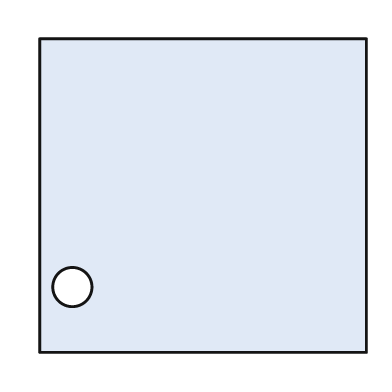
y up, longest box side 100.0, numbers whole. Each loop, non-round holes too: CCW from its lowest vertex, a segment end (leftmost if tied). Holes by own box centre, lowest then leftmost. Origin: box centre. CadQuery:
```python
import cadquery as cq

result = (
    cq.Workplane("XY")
    .moveTo(-50.0, -48.0)
    .lineTo(50.0, -48.0)
    .lineTo(50.0, 48.0)
    .lineTo(-50.0, 48.0)
    .close()
    .moveTo(-40.0, -28.0)
    .circle(6.0)
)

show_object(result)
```